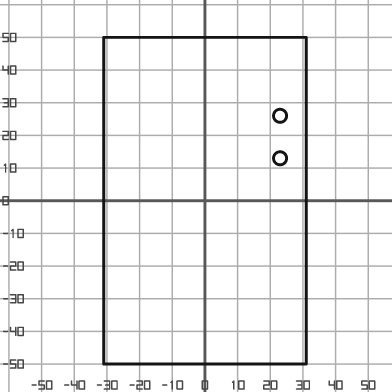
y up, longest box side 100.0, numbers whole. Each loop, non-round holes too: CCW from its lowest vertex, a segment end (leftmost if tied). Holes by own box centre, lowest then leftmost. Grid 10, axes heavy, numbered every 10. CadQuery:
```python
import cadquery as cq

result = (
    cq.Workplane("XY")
    .moveTo(-31.0, -50.0)
    .lineTo(31.0, -50.0)
    .lineTo(31.0, 50.0)
    .lineTo(-31.0, 50.0)
    .close()
    .moveTo(23.0, 13.0)
    .circle(2.0)
    .moveTo(23.0, 26.0)
    .circle(2.0)
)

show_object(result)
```